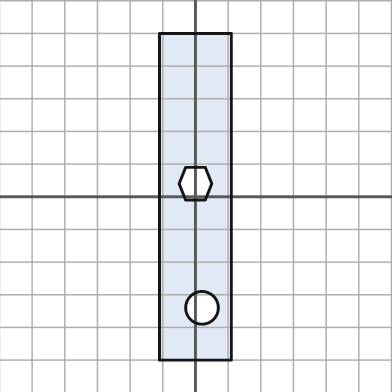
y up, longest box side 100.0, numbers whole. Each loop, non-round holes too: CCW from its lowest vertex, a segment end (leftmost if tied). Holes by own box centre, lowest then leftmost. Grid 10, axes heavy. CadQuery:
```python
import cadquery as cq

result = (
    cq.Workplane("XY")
    .moveTo(-11.0, -50.0)
    .lineTo(11.0, -50.0)
    .lineTo(11.0, 50.0)
    .lineTo(-11.0, 50.0)
    .close()
    .moveTo(2.0, -34.0)
    .circle(5.0)
    .moveTo(-3.0, -1.0)
    .lineTo(3.0, -1.0)
    .lineTo(5.0, 4.0)
    .lineTo(3.0, 9.0)
    .lineTo(-3.0, 9.0)
    .lineTo(-5.0, 4.0)
    .close()
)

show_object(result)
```